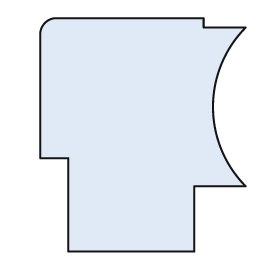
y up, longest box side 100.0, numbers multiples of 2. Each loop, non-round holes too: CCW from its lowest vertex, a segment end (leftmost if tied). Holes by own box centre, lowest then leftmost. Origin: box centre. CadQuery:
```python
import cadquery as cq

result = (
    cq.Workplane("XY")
    .moveTo(-32.0, -50.0)
    .lineTo(22.0, -50.0)
    .lineTo(22.0, -22.0)
    .lineTo(44.0, -22.0)
    .threePointArc((30.0, 12.0), (44.0, 46.0))
    .lineTo(26.0, 46.0)
    .lineTo(26.0, 50.0)
    .lineTo(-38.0, 50.0)
    .threePointArc((-42.0, 48.0), (-44.0, 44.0))
    .lineTo(-44.0, -10.0)
    .lineTo(-32.0, -10.0)
    .close()
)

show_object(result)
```